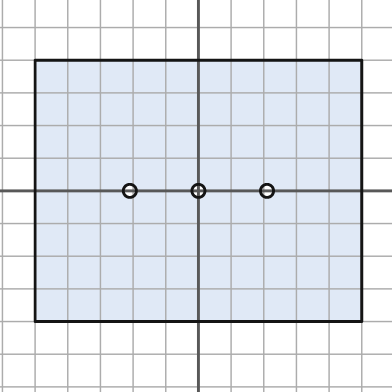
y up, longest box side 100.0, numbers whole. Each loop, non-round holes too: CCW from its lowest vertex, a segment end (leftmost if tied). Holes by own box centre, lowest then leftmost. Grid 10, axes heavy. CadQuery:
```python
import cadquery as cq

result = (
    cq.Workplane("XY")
    .moveTo(-50.0, -40.0)
    .lineTo(50.0, -40.0)
    .lineTo(50.0, 40.0)
    .lineTo(-50.0, 40.0)
    .close()
    .moveTo(-21.0, 0.0)
    .circle(2.0)
    .moveTo(0.0, 0.0)
    .circle(2.0)
    .moveTo(21.0, 0.0)
    .circle(2.0)
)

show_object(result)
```